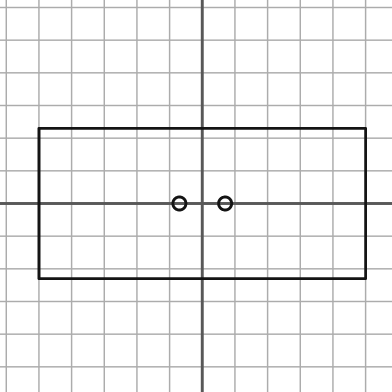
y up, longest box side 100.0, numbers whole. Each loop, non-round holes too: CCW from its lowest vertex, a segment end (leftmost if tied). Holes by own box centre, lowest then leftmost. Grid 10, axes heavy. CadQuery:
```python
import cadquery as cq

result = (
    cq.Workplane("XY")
    .moveTo(-50.0, -23.0)
    .lineTo(50.0, -23.0)
    .lineTo(50.0, 23.0)
    .lineTo(-50.0, 23.0)
    .close()
    .moveTo(-7.0, 0.0)
    .circle(2.0)
    .moveTo(7.0, 0.0)
    .circle(2.0)
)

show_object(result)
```